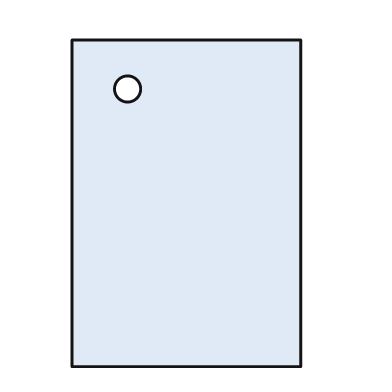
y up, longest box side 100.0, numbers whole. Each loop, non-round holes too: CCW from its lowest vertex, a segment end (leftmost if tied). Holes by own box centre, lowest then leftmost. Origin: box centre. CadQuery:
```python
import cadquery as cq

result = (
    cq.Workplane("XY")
    .moveTo(-35.0, -50.0)
    .lineTo(35.0, -50.0)
    .lineTo(35.0, 50.0)
    .lineTo(-35.0, 50.0)
    .close()
    .moveTo(-18.0, 35.0)
    .circle(4.0)
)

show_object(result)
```